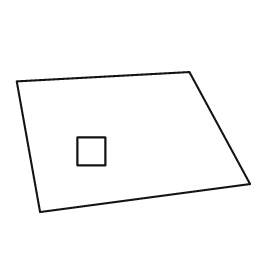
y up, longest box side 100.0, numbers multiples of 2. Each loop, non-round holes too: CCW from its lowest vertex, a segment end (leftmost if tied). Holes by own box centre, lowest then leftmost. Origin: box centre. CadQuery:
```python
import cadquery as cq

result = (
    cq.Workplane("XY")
    .moveTo(-40.0, -30.0)
    .lineTo(50.0, -18.0)
    .lineTo(24.0, 30.0)
    .lineTo(-50.0, 26.0)
    .close()
    .moveTo(-24.0, -10.0)
    .lineTo(-12.0, -10.0)
    .lineTo(-12.0, 2.0)
    .lineTo(-24.0, 2.0)
    .close()
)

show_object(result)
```